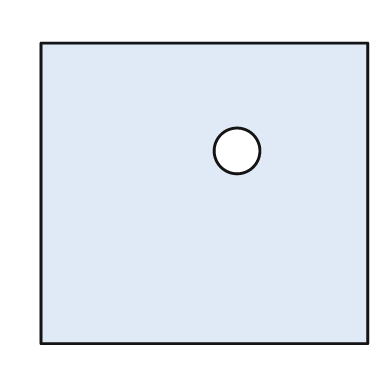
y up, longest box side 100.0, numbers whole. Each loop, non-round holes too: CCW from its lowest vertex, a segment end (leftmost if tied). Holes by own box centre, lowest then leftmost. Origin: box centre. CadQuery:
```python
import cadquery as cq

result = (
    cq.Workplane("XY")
    .moveTo(-50.0, -46.0)
    .lineTo(50.0, -46.0)
    .lineTo(50.0, 46.0)
    .lineTo(-50.0, 46.0)
    .close()
    .moveTo(10.0, 13.0)
    .circle(7.0)
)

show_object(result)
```